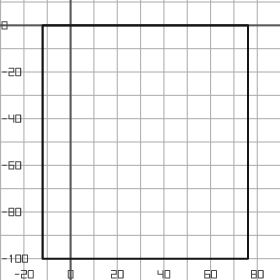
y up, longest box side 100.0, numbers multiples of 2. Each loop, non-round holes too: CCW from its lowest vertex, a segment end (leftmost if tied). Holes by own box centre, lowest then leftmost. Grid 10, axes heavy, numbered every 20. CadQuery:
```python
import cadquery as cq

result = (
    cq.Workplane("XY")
    .moveTo(-12.0, -100.0)
    .lineTo(76.0, -100.0)
    .lineTo(76.0, 0.0)
    .lineTo(-12.0, 0.0)
    .close()
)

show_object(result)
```